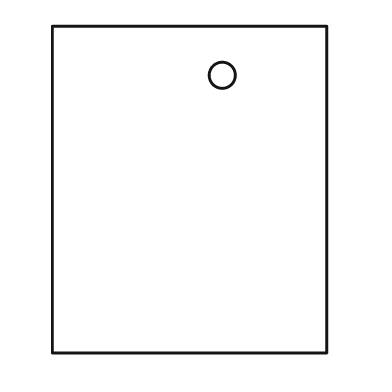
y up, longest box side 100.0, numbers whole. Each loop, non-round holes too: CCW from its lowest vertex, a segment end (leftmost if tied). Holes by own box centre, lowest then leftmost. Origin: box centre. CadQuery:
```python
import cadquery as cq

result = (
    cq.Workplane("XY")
    .moveTo(-42.0, -50.0)
    .lineTo(42.0, -50.0)
    .lineTo(42.0, 50.0)
    .lineTo(-42.0, 50.0)
    .close()
    .moveTo(10.0, 35.0)
    .circle(4.0)
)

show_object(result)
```